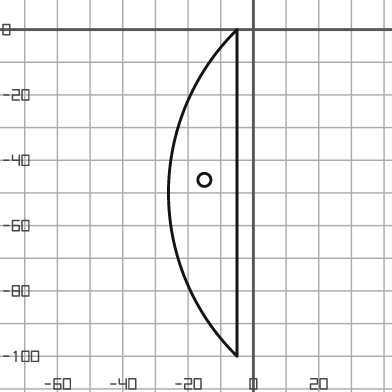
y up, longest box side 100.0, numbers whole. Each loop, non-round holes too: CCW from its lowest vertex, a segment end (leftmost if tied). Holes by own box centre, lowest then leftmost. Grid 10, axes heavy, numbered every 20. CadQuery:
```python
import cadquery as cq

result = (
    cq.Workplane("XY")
    .moveTo(-5.0, -100.0)
    .lineTo(-5.0, 0.0)
    .threePointArc((-26.0, -50.0), (-5.0, -100.0))
    .close()
    .moveTo(-15.0, -46.0)
    .circle(2.0)
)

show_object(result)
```